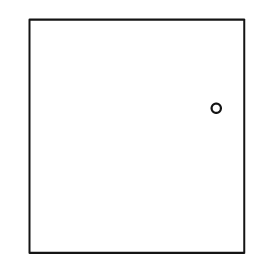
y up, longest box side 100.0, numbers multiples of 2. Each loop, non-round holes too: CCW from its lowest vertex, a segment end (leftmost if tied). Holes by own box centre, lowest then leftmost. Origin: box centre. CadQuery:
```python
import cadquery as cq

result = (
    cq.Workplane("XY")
    .moveTo(-46.0, -50.0)
    .lineTo(46.0, -50.0)
    .lineTo(46.0, 50.0)
    .lineTo(-46.0, 50.0)
    .close()
    .moveTo(34.0, 12.0)
    .circle(2.0)
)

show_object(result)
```